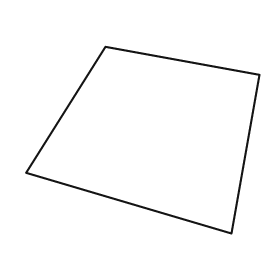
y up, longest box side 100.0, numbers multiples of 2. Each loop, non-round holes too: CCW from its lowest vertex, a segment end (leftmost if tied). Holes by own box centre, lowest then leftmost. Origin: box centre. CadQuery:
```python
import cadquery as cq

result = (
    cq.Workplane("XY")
    .moveTo(38.0, -40.0)
    .lineTo(50.0, 28.0)
    .lineTo(-16.0, 40.0)
    .lineTo(-50.0, -14.0)
    .close()
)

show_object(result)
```